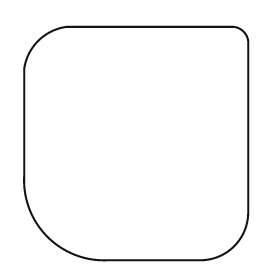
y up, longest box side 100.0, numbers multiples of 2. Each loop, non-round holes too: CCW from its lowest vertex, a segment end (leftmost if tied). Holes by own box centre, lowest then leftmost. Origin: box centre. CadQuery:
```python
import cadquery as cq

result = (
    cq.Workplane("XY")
    .moveTo(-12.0, -50.0)
    .lineTo(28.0, -50.0)
    .threePointArc((42.0, -44.0), (48.0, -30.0))
    .lineTo(48.0, 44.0)
    .threePointArc((46.0, 48.0), (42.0, 50.0))
    .lineTo(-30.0, 50.0)
    .threePointArc((-42.0, 44.0), (-48.0, 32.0))
    .lineTo(-48.0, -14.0)
    .threePointArc((-38.0, -40.0), (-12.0, -50.0))
    .close()
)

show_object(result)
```